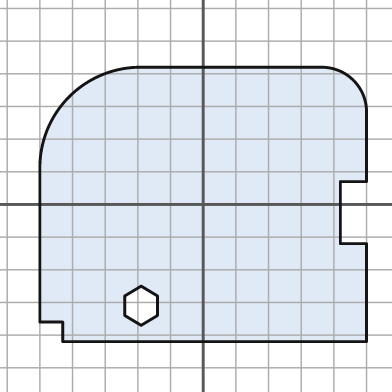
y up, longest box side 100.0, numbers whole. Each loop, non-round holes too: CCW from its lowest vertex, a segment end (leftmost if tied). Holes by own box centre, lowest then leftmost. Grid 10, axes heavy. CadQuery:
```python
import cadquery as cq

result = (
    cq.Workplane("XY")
    .moveTo(-43.0, -42.0)
    .lineTo(50.0, -42.0)
    .lineTo(50.0, -12.0)
    .lineTo(42.0, -12.0)
    .lineTo(42.0, 7.0)
    .lineTo(50.0, 7.0)
    .lineTo(50.0, 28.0)
    .threePointArc((46.0, 38.0), (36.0, 42.0))
    .lineTo(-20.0, 42.0)
    .threePointArc((-41.0, 33.0), (-50.0, 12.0))
    .lineTo(-50.0, -36.0)
    .lineTo(-43.0, -36.0)
    .close()
    .moveTo(-19.0, -37.0)
    .lineTo(-14.0, -34.0)
    .lineTo(-14.0, -28.0)
    .lineTo(-19.0, -25.0)
    .lineTo(-24.0, -28.0)
    .lineTo(-24.0, -34.0)
    .close()
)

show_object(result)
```